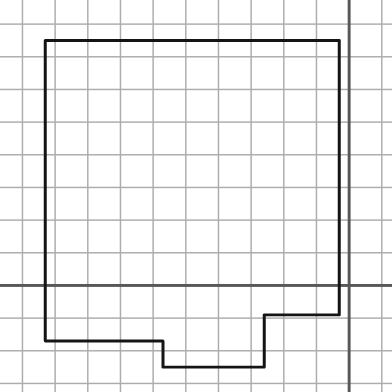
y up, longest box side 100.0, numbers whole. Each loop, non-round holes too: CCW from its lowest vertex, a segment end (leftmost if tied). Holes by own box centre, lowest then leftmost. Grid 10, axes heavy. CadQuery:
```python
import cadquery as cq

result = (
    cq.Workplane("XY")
    .moveTo(-57.0, -25.0)
    .lineTo(-26.0, -25.0)
    .lineTo(-26.0, -9.0)
    .lineTo(-3.0, -9.0)
    .lineTo(-3.0, 75.0)
    .lineTo(-93.0, 75.0)
    .lineTo(-93.0, -17.0)
    .lineTo(-57.0, -17.0)
    .close()
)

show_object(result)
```